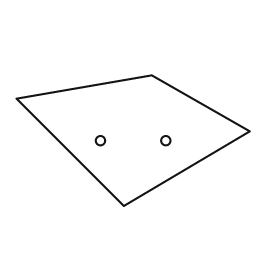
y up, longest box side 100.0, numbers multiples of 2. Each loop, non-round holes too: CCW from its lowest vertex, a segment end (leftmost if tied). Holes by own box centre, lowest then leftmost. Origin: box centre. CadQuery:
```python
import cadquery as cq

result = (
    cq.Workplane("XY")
    .moveTo(-4.0, -28.0)
    .lineTo(50.0, 4.0)
    .lineTo(8.0, 28.0)
    .lineTo(-50.0, 18.0)
    .close()
    .moveTo(-14.0, 0.0)
    .circle(2.0)
    .moveTo(14.0, 0.0)
    .circle(2.0)
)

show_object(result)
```